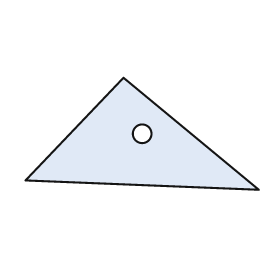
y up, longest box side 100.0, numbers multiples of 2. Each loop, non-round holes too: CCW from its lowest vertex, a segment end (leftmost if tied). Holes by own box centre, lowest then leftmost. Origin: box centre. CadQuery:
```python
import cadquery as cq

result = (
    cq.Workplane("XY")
    .moveTo(50.0, -24.0)
    .lineTo(-8.0, 24.0)
    .lineTo(-50.0, -20.0)
    .close()
    .moveTo(0.0, 0.0)
    .circle(4.0)
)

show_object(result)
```